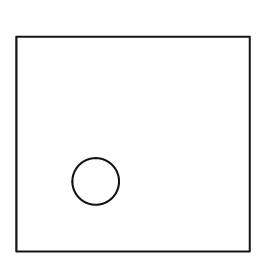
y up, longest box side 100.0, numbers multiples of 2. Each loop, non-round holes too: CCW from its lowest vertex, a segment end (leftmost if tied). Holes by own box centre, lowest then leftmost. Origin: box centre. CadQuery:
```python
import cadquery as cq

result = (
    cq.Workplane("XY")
    .moveTo(-50.0, -46.0)
    .lineTo(50.0, -46.0)
    .lineTo(50.0, 46.0)
    .lineTo(-50.0, 46.0)
    .close()
    .moveTo(-16.0, -16.0)
    .circle(10.0)
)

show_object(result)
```